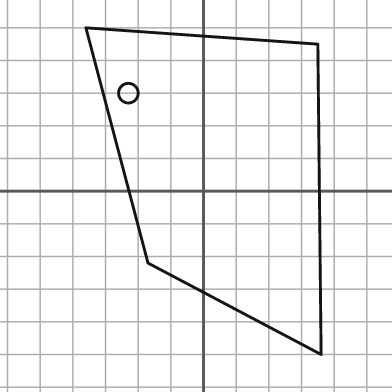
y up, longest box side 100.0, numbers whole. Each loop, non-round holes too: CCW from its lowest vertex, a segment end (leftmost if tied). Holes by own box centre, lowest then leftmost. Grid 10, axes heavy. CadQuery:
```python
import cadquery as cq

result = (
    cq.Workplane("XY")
    .moveTo(36.0, -50.0)
    .lineTo(35.0, 45.0)
    .lineTo(-36.0, 50.0)
    .lineTo(-17.0, -22.0)
    .close()
    .moveTo(-23.0, 30.0)
    .circle(3.0)
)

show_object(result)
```